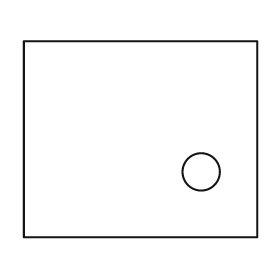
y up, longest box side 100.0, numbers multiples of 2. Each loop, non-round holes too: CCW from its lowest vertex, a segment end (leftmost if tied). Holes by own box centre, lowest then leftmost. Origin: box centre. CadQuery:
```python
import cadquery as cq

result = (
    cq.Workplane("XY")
    .moveTo(-50.0, -42.0)
    .lineTo(50.0, -42.0)
    .lineTo(50.0, 42.0)
    .lineTo(-50.0, 42.0)
    .close()
    .moveTo(26.0, -14.0)
    .circle(8.0)
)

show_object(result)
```